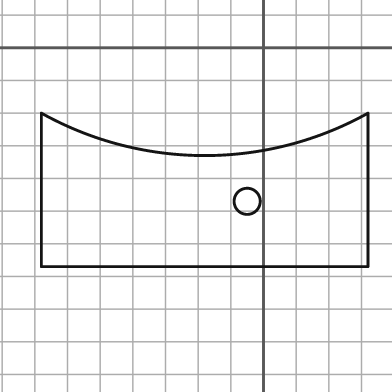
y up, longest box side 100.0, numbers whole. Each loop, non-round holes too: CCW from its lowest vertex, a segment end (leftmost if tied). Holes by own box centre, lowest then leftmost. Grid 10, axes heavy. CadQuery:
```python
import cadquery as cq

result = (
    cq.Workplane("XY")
    .moveTo(-68.0, -67.0)
    .lineTo(32.0, -67.0)
    .lineTo(32.0, -20.0)
    .threePointArc((-18.0, -33.0), (-68.0, -20.0))
    .close()
    .moveTo(-5.0, -47.0)
    .circle(4.0)
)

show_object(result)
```